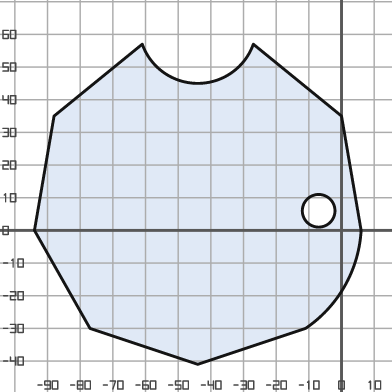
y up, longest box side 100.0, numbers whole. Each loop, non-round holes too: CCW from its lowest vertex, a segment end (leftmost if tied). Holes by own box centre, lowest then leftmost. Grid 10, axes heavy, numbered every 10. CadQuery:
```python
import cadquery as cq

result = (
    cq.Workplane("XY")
    .moveTo(-44.0, -41.0)
    .lineTo(-11.0, -30.0)
    .threePointArc((1.0, -17.0), (6.0, 0.0))
    .lineTo(0.0, 35.0)
    .lineTo(-27.0, 57.0)
    .threePointArc((-44.0, 45.0), (-61.0, 57.0))
    .lineTo(-88.0, 35.0)
    .lineTo(-94.0, 0.0)
    .lineTo(-77.0, -30.0)
    .close()
    .moveTo(-7.0, 6.0)
    .circle(5.0)
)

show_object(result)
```